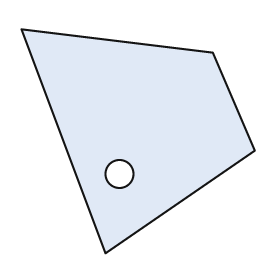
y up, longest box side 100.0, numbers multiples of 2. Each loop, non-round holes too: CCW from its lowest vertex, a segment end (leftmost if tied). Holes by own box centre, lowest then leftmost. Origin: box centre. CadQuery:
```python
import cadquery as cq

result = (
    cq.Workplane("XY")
    .moveTo(-14.0, -48.0)
    .lineTo(50.0, -4.0)
    .lineTo(32.0, 38.0)
    .lineTo(-50.0, 48.0)
    .close()
    .moveTo(-8.0, -14.0)
    .circle(6.0)
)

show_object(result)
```